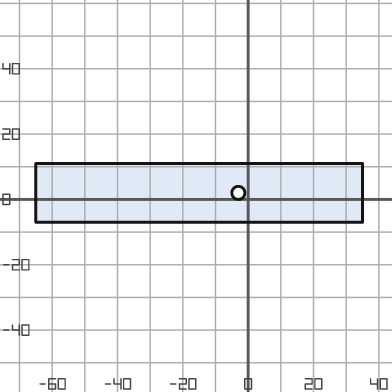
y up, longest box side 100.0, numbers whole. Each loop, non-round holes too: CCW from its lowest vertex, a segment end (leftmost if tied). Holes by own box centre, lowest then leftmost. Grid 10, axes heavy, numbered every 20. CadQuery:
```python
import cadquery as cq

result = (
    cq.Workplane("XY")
    .moveTo(-65.0, -7.0)
    .lineTo(35.0, -7.0)
    .lineTo(35.0, 11.0)
    .lineTo(-65.0, 11.0)
    .close()
    .moveTo(-3.0, 2.0)
    .circle(2.0)
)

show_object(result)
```